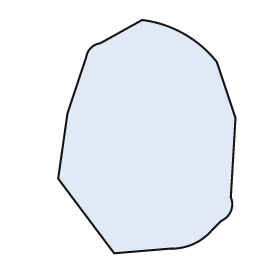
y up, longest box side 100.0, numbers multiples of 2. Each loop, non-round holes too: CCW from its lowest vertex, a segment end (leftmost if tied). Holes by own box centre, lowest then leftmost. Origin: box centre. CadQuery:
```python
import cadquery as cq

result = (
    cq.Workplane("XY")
    .moveTo(-14.0, -50.0)
    .lineTo(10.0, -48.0)
    .threePointArc((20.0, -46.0), (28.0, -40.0))
    .lineTo(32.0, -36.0)
    .threePointArc((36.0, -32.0), (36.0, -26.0))
    .lineTo(38.0, 8.0)
    .lineTo(30.0, 32.0)
    .threePointArc((16.0, 44.0), (-2.0, 50.0))
    .lineTo(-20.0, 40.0)
    .threePointArc((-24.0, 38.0), (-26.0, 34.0))
    .lineTo(-34.0, 10.0)
    .lineTo(-38.0, -18.0)
    .close()
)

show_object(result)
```